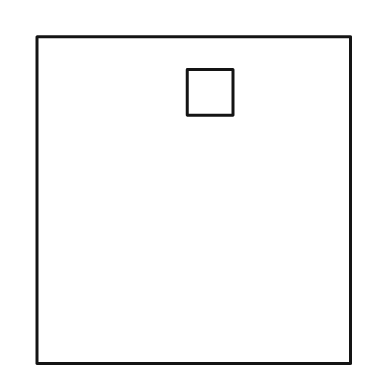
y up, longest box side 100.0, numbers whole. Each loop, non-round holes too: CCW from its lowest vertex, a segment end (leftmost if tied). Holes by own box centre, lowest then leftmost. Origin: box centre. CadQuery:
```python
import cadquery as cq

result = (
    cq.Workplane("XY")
    .moveTo(-48.0, -50.0)
    .lineTo(48.0, -50.0)
    .lineTo(48.0, 50.0)
    .lineTo(-48.0, 50.0)
    .close()
    .moveTo(-2.0, 26.0)
    .lineTo(12.0, 26.0)
    .lineTo(12.0, 40.0)
    .lineTo(-2.0, 40.0)
    .close()
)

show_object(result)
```